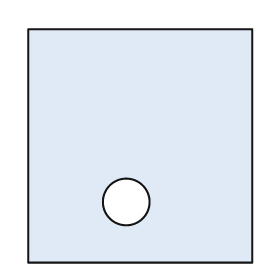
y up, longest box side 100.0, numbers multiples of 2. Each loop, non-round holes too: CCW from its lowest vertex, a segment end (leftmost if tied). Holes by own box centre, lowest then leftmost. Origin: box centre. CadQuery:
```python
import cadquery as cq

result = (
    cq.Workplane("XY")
    .moveTo(-48.0, -50.0)
    .lineTo(48.0, -50.0)
    .lineTo(48.0, 50.0)
    .lineTo(-48.0, 50.0)
    .close()
    .moveTo(-6.0, -24.0)
    .circle(10.0)
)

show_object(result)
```